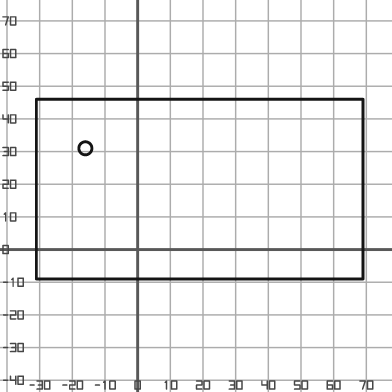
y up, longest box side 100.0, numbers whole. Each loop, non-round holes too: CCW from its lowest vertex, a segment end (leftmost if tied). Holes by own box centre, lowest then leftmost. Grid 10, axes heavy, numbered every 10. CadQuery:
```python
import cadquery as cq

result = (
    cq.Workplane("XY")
    .moveTo(-31.0, -9.0)
    .lineTo(69.0, -9.0)
    .lineTo(69.0, 46.0)
    .lineTo(-31.0, 46.0)
    .close()
    .moveTo(-16.0, 31.0)
    .circle(2.0)
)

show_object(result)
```